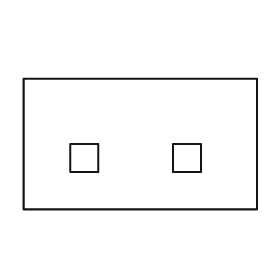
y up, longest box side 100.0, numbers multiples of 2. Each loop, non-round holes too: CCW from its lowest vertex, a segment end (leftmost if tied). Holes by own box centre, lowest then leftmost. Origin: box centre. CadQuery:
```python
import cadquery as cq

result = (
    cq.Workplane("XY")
    .moveTo(-50.0, -28.0)
    .lineTo(50.0, -28.0)
    .lineTo(50.0, 28.0)
    .lineTo(-50.0, 28.0)
    .close()
    .moveTo(-30.0, -12.0)
    .lineTo(-18.0, -12.0)
    .lineTo(-18.0, 0.0)
    .lineTo(-30.0, 0.0)
    .close()
    .moveTo(14.0, -12.0)
    .lineTo(26.0, -12.0)
    .lineTo(26.0, 0.0)
    .lineTo(14.0, 0.0)
    .close()
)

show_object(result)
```